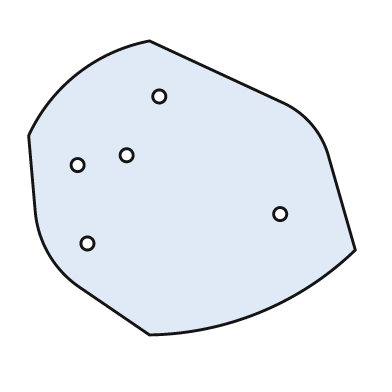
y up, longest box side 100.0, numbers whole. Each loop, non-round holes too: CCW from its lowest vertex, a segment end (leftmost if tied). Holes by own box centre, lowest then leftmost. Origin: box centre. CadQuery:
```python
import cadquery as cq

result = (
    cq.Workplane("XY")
    .moveTo(-13.0, -45.0)
    .threePointArc((21.0, -38.0), (50.0, -19.0))
    .lineTo(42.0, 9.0)
    .threePointArc((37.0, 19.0), (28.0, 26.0))
    .lineTo(-13.0, 45.0)
    .threePointArc((-35.0, 35.0), (-50.0, 16.0))
    .lineTo(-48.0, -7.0)
    .threePointArc((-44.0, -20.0), (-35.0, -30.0))
    .close()
    .moveTo(-32.0, -17.0)
    .circle(2.0)
    .moveTo(27.0, -8.0)
    .circle(2.0)
    .moveTo(-35.0, 7.0)
    .circle(2.0)
    .moveTo(-20.0, 10.0)
    .circle(2.0)
    .moveTo(-10.0, 28.0)
    .circle(2.0)
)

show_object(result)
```